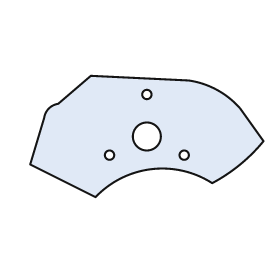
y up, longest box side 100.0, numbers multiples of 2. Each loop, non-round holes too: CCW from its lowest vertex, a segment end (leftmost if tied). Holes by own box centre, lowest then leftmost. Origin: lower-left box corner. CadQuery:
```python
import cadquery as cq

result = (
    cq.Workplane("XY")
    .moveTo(28.0, 0.0)
    .threePointArc((52.0, 12.0), (78.0, 6.0))
    .threePointArc((90.0, 14.0), (100.0, 24.0))
    .lineTo(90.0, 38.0)
    .threePointArc((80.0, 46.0), (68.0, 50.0))
    .lineTo(26.0, 52.0)
    .lineTo(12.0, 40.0)
    .threePointArc((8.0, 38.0), (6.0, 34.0))
    .lineTo(0.0, 14.0)
    .close()
    .moveTo(34.0, 18.0)
    .circle(2.0)
    .moveTo(66.0, 18.0)
    .circle(2.0)
    .moveTo(50.0, 26.0)
    .circle(6.0)
    .moveTo(50.0, 44.0)
    .circle(2.0)
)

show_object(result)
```